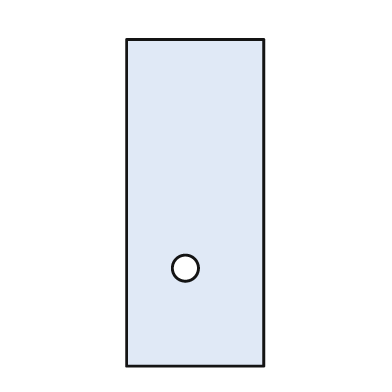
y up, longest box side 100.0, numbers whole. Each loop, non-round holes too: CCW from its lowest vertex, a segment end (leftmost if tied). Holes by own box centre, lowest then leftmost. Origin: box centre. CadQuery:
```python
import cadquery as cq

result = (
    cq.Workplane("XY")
    .moveTo(-21.0, -50.0)
    .lineTo(21.0, -50.0)
    .lineTo(21.0, 50.0)
    .lineTo(-21.0, 50.0)
    .close()
    .moveTo(-3.0, -20.0)
    .circle(4.0)
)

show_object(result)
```